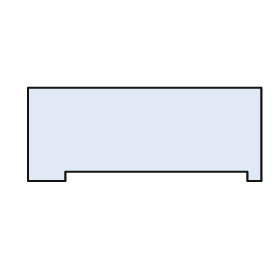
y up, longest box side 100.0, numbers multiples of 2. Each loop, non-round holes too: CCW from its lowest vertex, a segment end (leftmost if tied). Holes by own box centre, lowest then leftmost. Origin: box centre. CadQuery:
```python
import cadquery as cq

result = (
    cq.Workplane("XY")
    .moveTo(-50.0, -20.0)
    .lineTo(-34.0, -20.0)
    .lineTo(-34.0, -16.0)
    .lineTo(44.0, -16.0)
    .lineTo(44.0, -20.0)
    .lineTo(50.0, -20.0)
    .lineTo(50.0, 20.0)
    .lineTo(-50.0, 20.0)
    .close()
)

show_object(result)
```